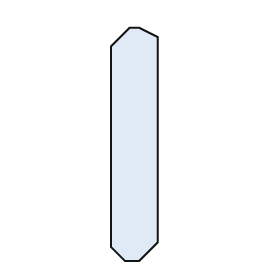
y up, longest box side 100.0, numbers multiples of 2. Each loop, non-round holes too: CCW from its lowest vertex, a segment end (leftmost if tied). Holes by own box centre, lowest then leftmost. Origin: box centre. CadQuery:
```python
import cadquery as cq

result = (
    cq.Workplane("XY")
    .moveTo(-4.0, -50.0)
    .lineTo(2.0, -50.0)
    .lineTo(10.0, -42.0)
    .lineTo(10.0, 46.0)
    .lineTo(2.0, 50.0)
    .lineTo(-2.0, 50.0)
    .lineTo(-10.0, 42.0)
    .lineTo(-10.0, -44.0)
    .close()
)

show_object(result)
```